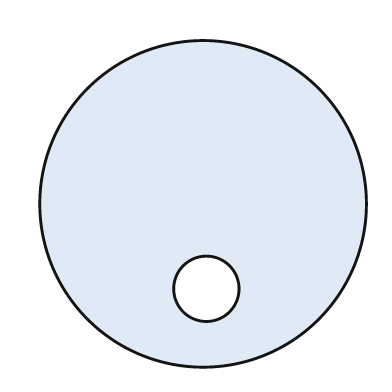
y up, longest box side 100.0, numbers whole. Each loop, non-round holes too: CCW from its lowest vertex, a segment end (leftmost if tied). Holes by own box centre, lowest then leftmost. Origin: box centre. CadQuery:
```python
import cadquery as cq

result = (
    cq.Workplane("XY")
    .moveTo(0.0, 0.0)
    .circle(50.0)
    .moveTo(1.0, -26.0)
    .circle(10.0)
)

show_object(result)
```